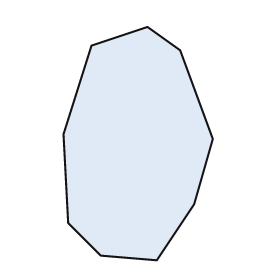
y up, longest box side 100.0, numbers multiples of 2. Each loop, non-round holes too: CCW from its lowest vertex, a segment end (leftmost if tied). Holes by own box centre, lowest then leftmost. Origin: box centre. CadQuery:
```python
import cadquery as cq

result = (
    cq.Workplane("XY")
    .moveTo(8.0, -50.0)
    .lineTo(24.0, -26.0)
    .lineTo(32.0, 2.0)
    .lineTo(18.0, 40.0)
    .lineTo(4.0, 50.0)
    .lineTo(-20.0, 42.0)
    .lineTo(-32.0, 4.0)
    .lineTo(-30.0, -34.0)
    .lineTo(-16.0, -48.0)
    .close()
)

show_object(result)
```